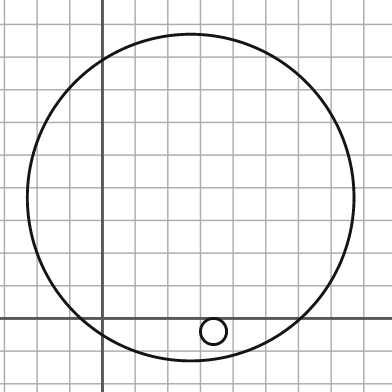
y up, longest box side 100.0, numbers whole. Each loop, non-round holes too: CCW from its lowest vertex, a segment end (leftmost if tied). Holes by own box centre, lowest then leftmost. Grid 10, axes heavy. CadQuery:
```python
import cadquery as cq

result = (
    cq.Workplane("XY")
    .moveTo(27.0, 37.0)
    .circle(50.0)
    .moveTo(34.0, -4.0)
    .circle(4.0)
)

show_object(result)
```